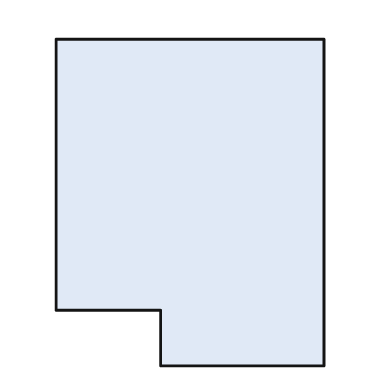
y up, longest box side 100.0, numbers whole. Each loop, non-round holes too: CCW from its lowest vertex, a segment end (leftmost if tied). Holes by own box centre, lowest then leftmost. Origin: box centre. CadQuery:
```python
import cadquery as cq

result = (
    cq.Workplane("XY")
    .moveTo(-9.0, -50.0)
    .lineTo(41.0, -50.0)
    .lineTo(41.0, 50.0)
    .lineTo(-41.0, 50.0)
    .lineTo(-41.0, -33.0)
    .lineTo(-9.0, -33.0)
    .close()
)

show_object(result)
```